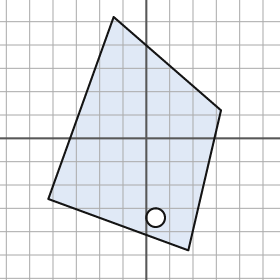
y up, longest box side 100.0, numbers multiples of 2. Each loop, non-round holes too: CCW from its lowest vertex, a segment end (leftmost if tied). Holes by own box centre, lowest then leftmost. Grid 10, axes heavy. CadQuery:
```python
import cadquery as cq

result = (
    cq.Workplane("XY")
    .moveTo(18.0, -48.0)
    .lineTo(32.0, 12.0)
    .lineTo(-14.0, 52.0)
    .lineTo(-42.0, -26.0)
    .close()
    .moveTo(4.0, -34.0)
    .circle(4.0)
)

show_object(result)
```